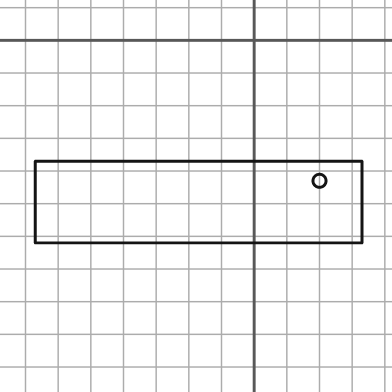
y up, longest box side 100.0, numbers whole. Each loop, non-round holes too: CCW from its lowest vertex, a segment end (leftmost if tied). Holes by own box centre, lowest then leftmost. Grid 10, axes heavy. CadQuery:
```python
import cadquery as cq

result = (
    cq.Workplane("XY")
    .moveTo(-67.0, -62.0)
    .lineTo(33.0, -62.0)
    .lineTo(33.0, -37.0)
    .lineTo(-67.0, -37.0)
    .close()
    .moveTo(20.0, -43.0)
    .circle(2.0)
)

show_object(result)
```